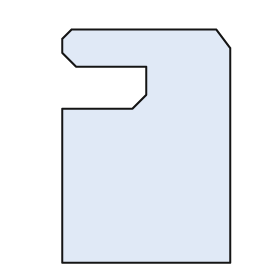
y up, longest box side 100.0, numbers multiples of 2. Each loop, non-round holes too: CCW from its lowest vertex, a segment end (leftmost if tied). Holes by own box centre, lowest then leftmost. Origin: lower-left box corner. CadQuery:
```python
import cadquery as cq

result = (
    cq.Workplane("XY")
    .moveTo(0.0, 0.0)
    .lineTo(72.0, 0.0)
    .lineTo(72.0, 92.0)
    .lineTo(66.0, 100.0)
    .lineTo(4.0, 100.0)
    .lineTo(0.0, 96.0)
    .lineTo(0.0, 90.0)
    .lineTo(6.0, 84.0)
    .lineTo(36.0, 84.0)
    .lineTo(36.0, 72.0)
    .lineTo(30.0, 66.0)
    .lineTo(0.0, 66.0)
    .close()
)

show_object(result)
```